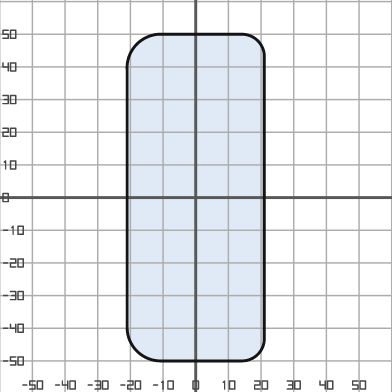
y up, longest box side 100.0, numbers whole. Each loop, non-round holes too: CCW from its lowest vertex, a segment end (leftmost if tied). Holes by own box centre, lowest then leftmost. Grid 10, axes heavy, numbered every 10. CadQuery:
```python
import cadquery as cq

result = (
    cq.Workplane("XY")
    .moveTo(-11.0, -50.0)
    .lineTo(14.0, -50.0)
    .threePointArc((19.0, -48.0), (21.0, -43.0))
    .lineTo(21.0, 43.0)
    .threePointArc((19.0, 48.0), (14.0, 50.0))
    .lineTo(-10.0, 50.0)
    .threePointArc((-18.0, 47.0), (-21.0, 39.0))
    .lineTo(-21.0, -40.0)
    .threePointArc((-18.0, -47.0), (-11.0, -50.0))
    .close()
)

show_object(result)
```